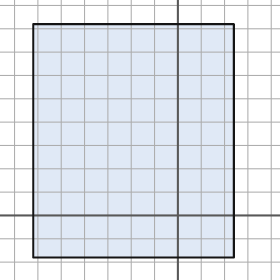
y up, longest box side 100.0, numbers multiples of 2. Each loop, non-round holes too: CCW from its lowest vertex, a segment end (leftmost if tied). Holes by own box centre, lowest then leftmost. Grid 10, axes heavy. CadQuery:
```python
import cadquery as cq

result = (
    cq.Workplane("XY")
    .moveTo(-62.0, -18.0)
    .lineTo(24.0, -18.0)
    .lineTo(24.0, 82.0)
    .lineTo(-62.0, 82.0)
    .close()
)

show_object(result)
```